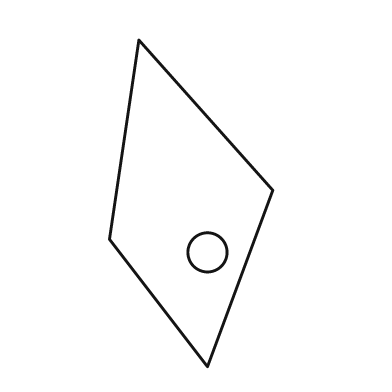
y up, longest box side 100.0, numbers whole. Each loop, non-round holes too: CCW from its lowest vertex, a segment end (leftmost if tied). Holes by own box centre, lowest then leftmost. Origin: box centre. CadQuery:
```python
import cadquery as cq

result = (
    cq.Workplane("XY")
    .moveTo(5.0, -50.0)
    .lineTo(25.0, 4.0)
    .lineTo(-16.0, 50.0)
    .lineTo(-25.0, -11.0)
    .close()
    .moveTo(5.0, -15.0)
    .circle(6.0)
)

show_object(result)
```